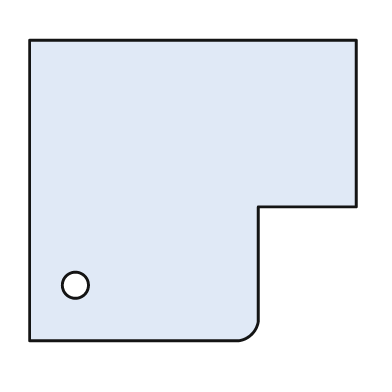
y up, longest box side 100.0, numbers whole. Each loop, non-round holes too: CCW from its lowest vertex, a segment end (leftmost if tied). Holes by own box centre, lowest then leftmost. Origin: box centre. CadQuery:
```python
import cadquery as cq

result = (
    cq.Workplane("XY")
    .moveTo(-50.0, -46.0)
    .lineTo(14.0, -46.0)
    .threePointArc((18.0, -44.0), (20.0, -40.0))
    .lineTo(20.0, -5.0)
    .lineTo(50.0, -5.0)
    .lineTo(50.0, 46.0)
    .lineTo(-50.0, 46.0)
    .close()
    .moveTo(-36.0, -29.0)
    .circle(4.0)
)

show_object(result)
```